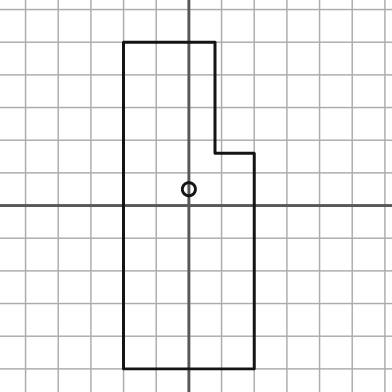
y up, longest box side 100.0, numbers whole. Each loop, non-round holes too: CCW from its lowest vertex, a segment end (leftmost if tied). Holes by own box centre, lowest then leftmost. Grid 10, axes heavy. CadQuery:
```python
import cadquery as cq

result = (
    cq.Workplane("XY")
    .moveTo(-20.0, -50.0)
    .lineTo(20.0, -50.0)
    .lineTo(20.0, 16.0)
    .lineTo(8.0, 16.0)
    .lineTo(8.0, 50.0)
    .lineTo(-20.0, 50.0)
    .close()
    .moveTo(0.0, 5.0)
    .circle(2.0)
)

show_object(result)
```